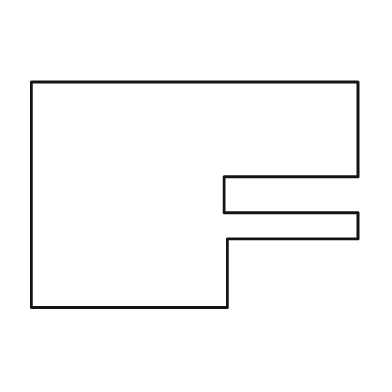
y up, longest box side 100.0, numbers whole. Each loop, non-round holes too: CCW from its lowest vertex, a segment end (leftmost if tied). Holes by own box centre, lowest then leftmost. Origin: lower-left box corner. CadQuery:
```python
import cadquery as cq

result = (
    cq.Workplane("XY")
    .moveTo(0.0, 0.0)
    .lineTo(60.0, 0.0)
    .lineTo(60.0, 21.0)
    .lineTo(100.0, 21.0)
    .lineTo(100.0, 29.0)
    .lineTo(59.0, 29.0)
    .lineTo(59.0, 40.0)
    .lineTo(100.0, 40.0)
    .lineTo(100.0, 69.0)
    .lineTo(0.0, 69.0)
    .close()
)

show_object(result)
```